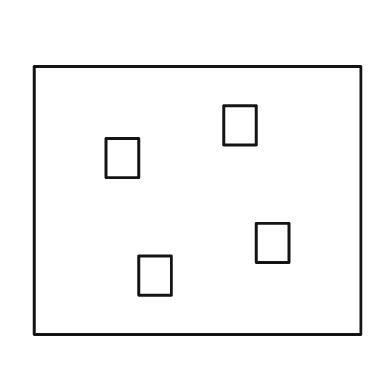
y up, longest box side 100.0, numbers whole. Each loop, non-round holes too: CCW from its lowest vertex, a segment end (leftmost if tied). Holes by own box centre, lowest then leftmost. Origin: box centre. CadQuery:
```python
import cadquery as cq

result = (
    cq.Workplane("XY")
    .moveTo(-50.0, -41.0)
    .lineTo(50.0, -41.0)
    .lineTo(50.0, 41.0)
    .lineTo(-50.0, 41.0)
    .close()
    .moveTo(-18.0, -29.0)
    .lineTo(-8.0, -29.0)
    .lineTo(-8.0, -17.0)
    .lineTo(-18.0, -17.0)
    .close()
    .moveTo(18.0, -19.0)
    .lineTo(28.0, -19.0)
    .lineTo(28.0, -7.0)
    .lineTo(18.0, -7.0)
    .close()
    .moveTo(-28.0, 7.0)
    .lineTo(-18.0, 7.0)
    .lineTo(-18.0, 19.0)
    .lineTo(-28.0, 19.0)
    .close()
    .moveTo(8.0, 17.0)
    .lineTo(18.0, 17.0)
    .lineTo(18.0, 29.0)
    .lineTo(8.0, 29.0)
    .close()
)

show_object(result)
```